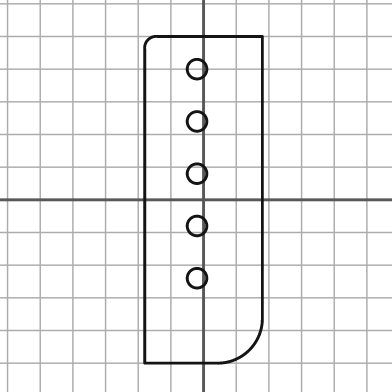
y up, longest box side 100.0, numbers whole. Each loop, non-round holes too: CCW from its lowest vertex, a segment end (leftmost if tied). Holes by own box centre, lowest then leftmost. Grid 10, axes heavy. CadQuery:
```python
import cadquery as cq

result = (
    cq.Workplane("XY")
    .moveTo(-18.0, -50.0)
    .lineTo(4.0, -50.0)
    .threePointArc((14.0, -46.0), (18.0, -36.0))
    .lineTo(18.0, 50.0)
    .lineTo(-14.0, 50.0)
    .threePointArc((-17.0, 49.0), (-18.0, 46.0))
    .close()
    .moveTo(-2.0, -24.0)
    .circle(3.0)
    .moveTo(-2.0, -8.0)
    .circle(3.0)
    .moveTo(-2.0, 8.0)
    .circle(3.0)
    .moveTo(-2.0, 24.0)
    .circle(3.0)
    .moveTo(-2.0, 40.0)
    .circle(3.0)
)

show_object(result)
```